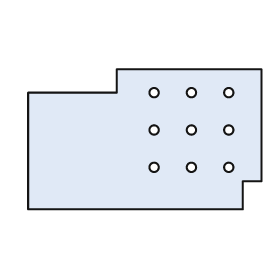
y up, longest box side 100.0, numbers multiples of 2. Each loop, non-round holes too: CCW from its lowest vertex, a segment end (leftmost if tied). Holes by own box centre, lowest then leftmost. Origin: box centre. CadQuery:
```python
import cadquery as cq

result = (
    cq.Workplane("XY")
    .moveTo(-50.0, -30.0)
    .lineTo(42.0, -30.0)
    .lineTo(42.0, -18.0)
    .lineTo(50.0, -18.0)
    .lineTo(50.0, 30.0)
    .lineTo(-12.0, 30.0)
    .lineTo(-12.0, 20.0)
    .lineTo(-50.0, 20.0)
    .close()
    .moveTo(4.0, -12.0)
    .circle(2.0)
    .moveTo(20.0, -12.0)
    .circle(2.0)
    .moveTo(36.0, -12.0)
    .circle(2.0)
    .moveTo(4.0, 4.0)
    .circle(2.0)
    .moveTo(20.0, 4.0)
    .circle(2.0)
    .moveTo(36.0, 4.0)
    .circle(2.0)
    .moveTo(4.0, 20.0)
    .circle(2.0)
    .moveTo(20.0, 20.0)
    .circle(2.0)
    .moveTo(36.0, 20.0)
    .circle(2.0)
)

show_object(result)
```